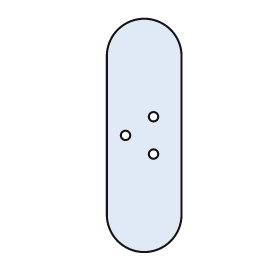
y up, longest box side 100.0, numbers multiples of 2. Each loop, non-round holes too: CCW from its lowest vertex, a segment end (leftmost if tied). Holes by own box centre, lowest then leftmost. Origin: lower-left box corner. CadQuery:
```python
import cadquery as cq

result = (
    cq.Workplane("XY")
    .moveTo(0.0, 16.0)
    .threePointArc((16.0, 0.0), (32.0, 16.0))
    .lineTo(32.0, 84.0)
    .threePointArc((16.0, 100.0), (0.0, 84.0))
    .close()
    .moveTo(20.0, 42.0)
    .circle(2.0)
    .moveTo(8.0, 50.0)
    .circle(2.0)
    .moveTo(20.0, 58.0)
    .circle(2.0)
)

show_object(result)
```